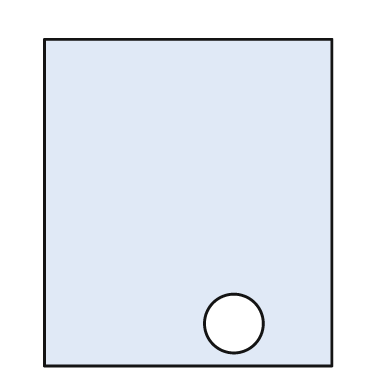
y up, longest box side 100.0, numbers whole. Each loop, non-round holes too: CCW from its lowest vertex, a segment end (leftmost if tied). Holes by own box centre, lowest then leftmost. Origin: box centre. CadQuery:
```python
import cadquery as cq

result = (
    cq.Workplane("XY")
    .moveTo(-44.0, -50.0)
    .lineTo(44.0, -50.0)
    .lineTo(44.0, 50.0)
    .lineTo(-44.0, 50.0)
    .close()
    .moveTo(14.0, -37.0)
    .circle(9.0)
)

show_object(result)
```